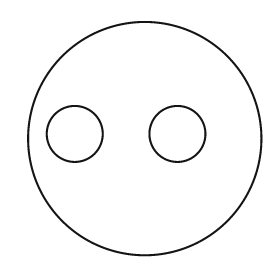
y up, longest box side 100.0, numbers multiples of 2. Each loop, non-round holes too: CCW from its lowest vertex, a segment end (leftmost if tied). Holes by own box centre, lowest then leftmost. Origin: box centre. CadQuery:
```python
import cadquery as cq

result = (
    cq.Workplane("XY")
    .moveTo(0.0, 0.0)
    .circle(50.0)
    .moveTo(-30.0, 2.0)
    .circle(12.0)
    .moveTo(14.0, 2.0)
    .circle(12.0)
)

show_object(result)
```